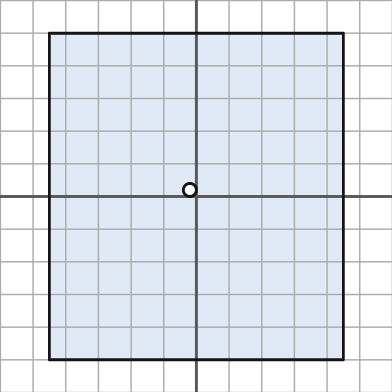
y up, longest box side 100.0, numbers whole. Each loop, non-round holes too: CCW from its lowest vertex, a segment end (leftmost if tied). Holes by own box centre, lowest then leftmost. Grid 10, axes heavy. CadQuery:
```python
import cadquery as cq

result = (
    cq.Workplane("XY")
    .moveTo(-45.0, -50.0)
    .lineTo(45.0, -50.0)
    .lineTo(45.0, 50.0)
    .lineTo(-45.0, 50.0)
    .close()
    .moveTo(-2.0, 2.0)
    .circle(2.0)
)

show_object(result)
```